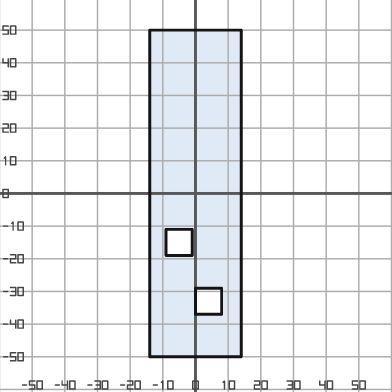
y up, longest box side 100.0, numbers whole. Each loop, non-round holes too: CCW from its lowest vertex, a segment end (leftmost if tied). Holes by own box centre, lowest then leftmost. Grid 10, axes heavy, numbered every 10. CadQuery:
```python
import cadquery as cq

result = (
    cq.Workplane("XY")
    .moveTo(-14.0, -50.0)
    .lineTo(14.0, -50.0)
    .lineTo(14.0, 50.0)
    .lineTo(-14.0, 50.0)
    .close()
    .moveTo(0.0, -37.0)
    .lineTo(8.0, -37.0)
    .lineTo(8.0, -29.0)
    .lineTo(0.0, -29.0)
    .close()
    .moveTo(-9.0, -19.0)
    .lineTo(-1.0, -19.0)
    .lineTo(-1.0, -11.0)
    .lineTo(-9.0, -11.0)
    .close()
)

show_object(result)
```